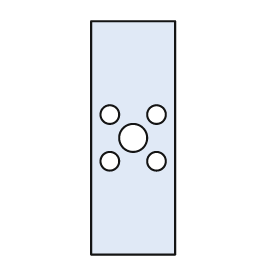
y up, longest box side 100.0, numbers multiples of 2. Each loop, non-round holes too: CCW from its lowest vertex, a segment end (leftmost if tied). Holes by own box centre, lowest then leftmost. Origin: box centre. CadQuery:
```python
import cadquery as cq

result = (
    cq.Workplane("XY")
    .moveTo(-18.0, -50.0)
    .lineTo(18.0, -50.0)
    .lineTo(18.0, 50.0)
    .lineTo(-18.0, 50.0)
    .close()
    .moveTo(-10.0, -10.0)
    .circle(4.0)
    .moveTo(10.0, -10.0)
    .circle(4.0)
    .moveTo(0.0, 0.0)
    .circle(6.0)
    .moveTo(-10.0, 10.0)
    .circle(4.0)
    .moveTo(10.0, 10.0)
    .circle(4.0)
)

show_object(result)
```